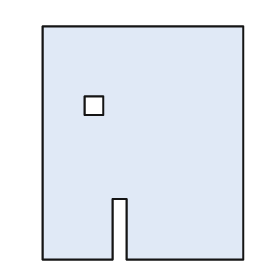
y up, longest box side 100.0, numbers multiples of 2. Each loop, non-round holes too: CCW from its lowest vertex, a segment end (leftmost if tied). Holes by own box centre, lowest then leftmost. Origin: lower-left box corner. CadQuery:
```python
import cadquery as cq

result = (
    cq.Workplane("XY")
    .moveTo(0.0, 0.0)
    .lineTo(30.0, 0.0)
    .lineTo(30.0, 26.0)
    .lineTo(36.0, 26.0)
    .lineTo(36.0, 0.0)
    .lineTo(86.0, 0.0)
    .lineTo(86.0, 100.0)
    .lineTo(0.0, 100.0)
    .close()
    .moveTo(18.0, 62.0)
    .lineTo(26.0, 62.0)
    .lineTo(26.0, 70.0)
    .lineTo(18.0, 70.0)
    .close()
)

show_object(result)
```